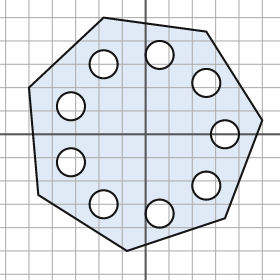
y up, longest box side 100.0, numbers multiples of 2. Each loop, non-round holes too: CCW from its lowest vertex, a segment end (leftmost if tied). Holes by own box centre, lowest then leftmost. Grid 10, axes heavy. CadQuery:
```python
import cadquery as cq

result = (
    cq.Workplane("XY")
    .moveTo(-8.0, -50.0)
    .lineTo(34.0, -36.0)
    .lineTo(50.0, 6.0)
    .lineTo(26.0, 44.0)
    .lineTo(-18.0, 50.0)
    .lineTo(-50.0, 20.0)
    .lineTo(-46.0, -26.0)
    .close()
    .moveTo(6.0, -34.0)
    .circle(6.0)
    .moveTo(-18.0, -30.0)
    .circle(6.0)
    .moveTo(26.0, -22.0)
    .circle(6.0)
    .moveTo(-32.0, -12.0)
    .circle(6.0)
    .moveTo(34.0, 0.0)
    .circle(6.0)
    .moveTo(-32.0, 12.0)
    .circle(6.0)
    .moveTo(26.0, 22.0)
    .circle(6.0)
    .moveTo(-18.0, 30.0)
    .circle(6.0)
    .moveTo(6.0, 34.0)
    .circle(6.0)
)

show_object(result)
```